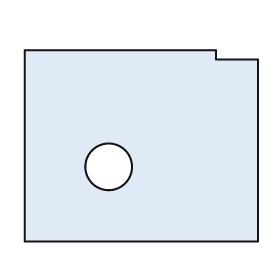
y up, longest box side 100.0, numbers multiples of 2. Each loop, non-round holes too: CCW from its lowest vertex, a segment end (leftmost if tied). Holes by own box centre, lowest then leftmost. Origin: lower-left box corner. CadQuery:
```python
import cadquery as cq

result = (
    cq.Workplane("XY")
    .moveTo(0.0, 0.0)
    .lineTo(100.0, 0.0)
    .lineTo(100.0, 78.0)
    .lineTo(82.0, 78.0)
    .lineTo(82.0, 82.0)
    .lineTo(0.0, 82.0)
    .close()
    .moveTo(36.0, 32.0)
    .circle(10.0)
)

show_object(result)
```